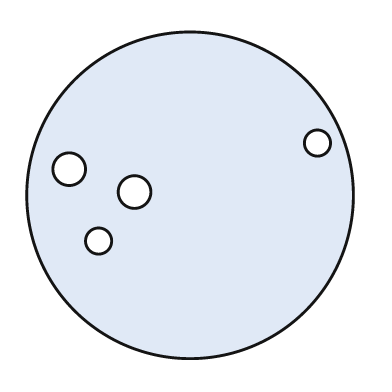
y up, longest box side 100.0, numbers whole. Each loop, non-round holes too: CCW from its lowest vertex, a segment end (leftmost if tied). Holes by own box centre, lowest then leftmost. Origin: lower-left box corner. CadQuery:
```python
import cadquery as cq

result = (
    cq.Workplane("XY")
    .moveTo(50.0, 50.0)
    .circle(50.0)
    .moveTo(22.0, 36.0)
    .circle(4.0)
    .moveTo(33.0, 51.0)
    .circle(5.0)
    .moveTo(13.0, 58.0)
    .circle(5.0)
    .moveTo(89.0, 66.0)
    .circle(4.0)
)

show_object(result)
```